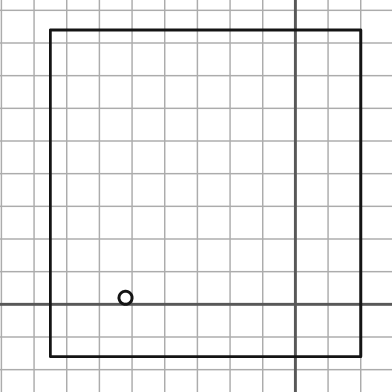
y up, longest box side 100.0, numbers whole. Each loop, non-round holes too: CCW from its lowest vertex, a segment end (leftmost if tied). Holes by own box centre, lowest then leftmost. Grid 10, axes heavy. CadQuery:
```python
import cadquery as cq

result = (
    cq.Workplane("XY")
    .moveTo(-75.0, -16.0)
    .lineTo(20.0, -16.0)
    .lineTo(20.0, 84.0)
    .lineTo(-75.0, 84.0)
    .close()
    .moveTo(-52.0, 2.0)
    .circle(2.0)
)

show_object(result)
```